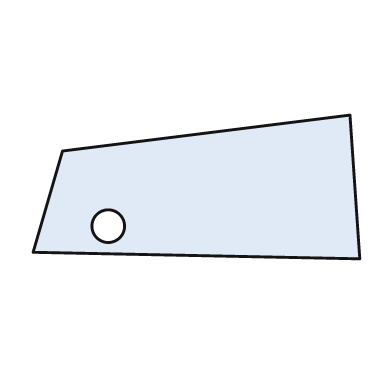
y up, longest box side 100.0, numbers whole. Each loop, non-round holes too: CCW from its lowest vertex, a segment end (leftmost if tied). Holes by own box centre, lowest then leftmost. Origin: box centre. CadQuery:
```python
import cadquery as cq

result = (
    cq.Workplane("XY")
    .moveTo(50.0, -22.0)
    .lineTo(47.0, 22.0)
    .lineTo(-41.0, 11.0)
    .lineTo(-50.0, -20.0)
    .close()
    .moveTo(-27.0, -12.0)
    .circle(5.0)
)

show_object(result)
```